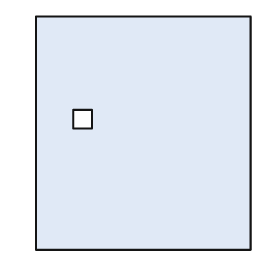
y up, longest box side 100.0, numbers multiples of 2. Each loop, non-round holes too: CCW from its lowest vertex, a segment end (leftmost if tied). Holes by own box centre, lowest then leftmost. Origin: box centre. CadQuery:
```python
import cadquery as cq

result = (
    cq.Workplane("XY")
    .moveTo(-46.0, -50.0)
    .lineTo(46.0, -50.0)
    .lineTo(46.0, 50.0)
    .lineTo(-46.0, 50.0)
    .close()
    .moveTo(-30.0, 2.0)
    .lineTo(-22.0, 2.0)
    .lineTo(-22.0, 10.0)
    .lineTo(-30.0, 10.0)
    .close()
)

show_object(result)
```